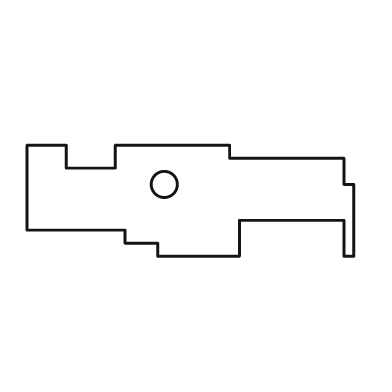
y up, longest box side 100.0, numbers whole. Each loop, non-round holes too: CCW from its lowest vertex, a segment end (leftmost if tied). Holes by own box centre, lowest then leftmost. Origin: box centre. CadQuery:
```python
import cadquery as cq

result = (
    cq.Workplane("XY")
    .moveTo(-10.0, -17.0)
    .lineTo(15.0, -17.0)
    .lineTo(15.0, -6.0)
    .lineTo(47.0, -6.0)
    .lineTo(47.0, -17.0)
    .lineTo(50.0, -17.0)
    .lineTo(50.0, 5.0)
    .lineTo(47.0, 5.0)
    .lineTo(47.0, 13.0)
    .lineTo(12.0, 13.0)
    .lineTo(12.0, 17.0)
    .lineTo(-23.0, 17.0)
    .lineTo(-23.0, 10.0)
    .lineTo(-38.0, 10.0)
    .lineTo(-38.0, 17.0)
    .lineTo(-50.0, 17.0)
    .lineTo(-50.0, -9.0)
    .lineTo(-20.0, -9.0)
    .lineTo(-20.0, -13.0)
    .lineTo(-10.0, -13.0)
    .close()
    .moveTo(-8.0, 5.0)
    .circle(4.0)
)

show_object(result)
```